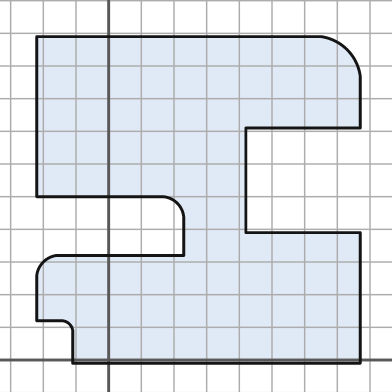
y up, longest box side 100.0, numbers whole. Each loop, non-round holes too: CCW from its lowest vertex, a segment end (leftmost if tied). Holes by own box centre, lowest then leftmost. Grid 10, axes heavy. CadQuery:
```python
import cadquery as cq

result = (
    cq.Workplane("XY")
    .moveTo(-11.0, -1.0)
    .lineTo(77.0, -1.0)
    .lineTo(77.0, 39.0)
    .lineTo(42.0, 39.0)
    .lineTo(42.0, 71.0)
    .lineTo(77.0, 71.0)
    .lineTo(77.0, 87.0)
    .threePointArc((73.0, 95.0), (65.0, 99.0))
    .lineTo(-22.0, 99.0)
    .lineTo(-22.0, 50.0)
    .lineTo(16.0, 50.0)
    .threePointArc((21.0, 48.0), (23.0, 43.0))
    .lineTo(23.0, 32.0)
    .lineTo(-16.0, 32.0)
    .threePointArc((-20.0, 30.0), (-22.0, 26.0))
    .lineTo(-22.0, 12.0)
    .lineTo(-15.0, 12.0)
    .threePointArc((-12.0, 11.0), (-11.0, 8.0))
    .close()
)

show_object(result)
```